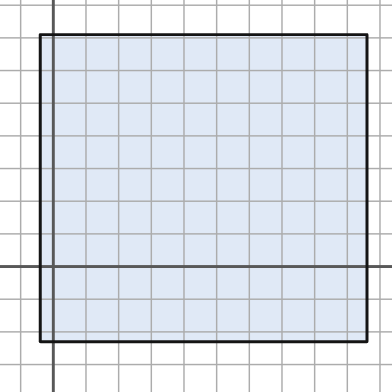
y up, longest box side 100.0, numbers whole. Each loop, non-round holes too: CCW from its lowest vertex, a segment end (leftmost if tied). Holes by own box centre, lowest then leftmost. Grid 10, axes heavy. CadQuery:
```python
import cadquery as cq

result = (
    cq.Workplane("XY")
    .moveTo(-4.0, -23.0)
    .lineTo(96.0, -23.0)
    .lineTo(96.0, 71.0)
    .lineTo(-4.0, 71.0)
    .close()
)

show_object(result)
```